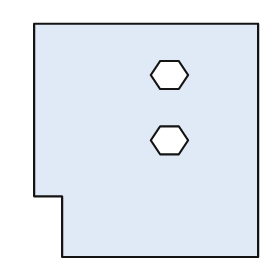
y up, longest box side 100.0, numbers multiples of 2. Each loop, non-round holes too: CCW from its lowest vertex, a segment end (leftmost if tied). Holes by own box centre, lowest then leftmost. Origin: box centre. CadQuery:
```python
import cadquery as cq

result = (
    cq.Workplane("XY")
    .moveTo(-36.0, -50.0)
    .lineTo(48.0, -50.0)
    .lineTo(48.0, 50.0)
    .lineTo(-48.0, 50.0)
    .lineTo(-48.0, -24.0)
    .lineTo(-36.0, -24.0)
    .close()
    .moveTo(6.0, -6.0)
    .lineTo(14.0, -6.0)
    .lineTo(18.0, 0.0)
    .lineTo(14.0, 6.0)
    .lineTo(6.0, 6.0)
    .lineTo(2.0, 0.0)
    .close()
    .moveTo(6.0, 22.0)
    .lineTo(14.0, 22.0)
    .lineTo(18.0, 28.0)
    .lineTo(14.0, 34.0)
    .lineTo(6.0, 34.0)
    .lineTo(2.0, 28.0)
    .close()
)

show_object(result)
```